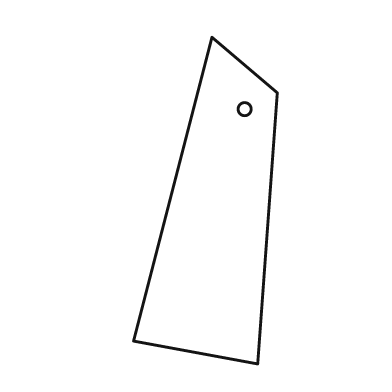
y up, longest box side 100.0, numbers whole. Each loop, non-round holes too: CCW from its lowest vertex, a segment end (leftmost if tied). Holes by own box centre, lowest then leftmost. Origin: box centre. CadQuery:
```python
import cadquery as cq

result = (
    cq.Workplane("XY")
    .moveTo(16.0, -50.0)
    .lineTo(22.0, 33.0)
    .lineTo(2.0, 50.0)
    .lineTo(-22.0, -43.0)
    .close()
    .moveTo(12.0, 28.0)
    .circle(2.0)
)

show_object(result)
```